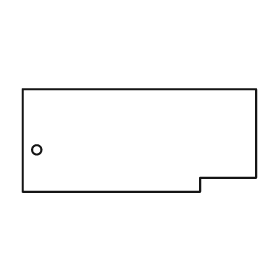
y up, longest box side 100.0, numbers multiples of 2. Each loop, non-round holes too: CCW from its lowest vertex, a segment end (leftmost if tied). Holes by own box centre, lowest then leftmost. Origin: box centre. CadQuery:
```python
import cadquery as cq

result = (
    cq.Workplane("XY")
    .moveTo(-50.0, -22.0)
    .lineTo(26.0, -22.0)
    .lineTo(26.0, -16.0)
    .lineTo(50.0, -16.0)
    .lineTo(50.0, 22.0)
    .lineTo(-50.0, 22.0)
    .close()
    .moveTo(-44.0, -4.0)
    .circle(2.0)
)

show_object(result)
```